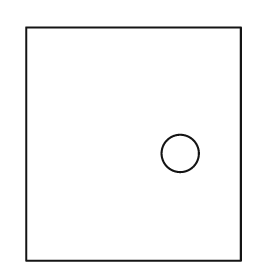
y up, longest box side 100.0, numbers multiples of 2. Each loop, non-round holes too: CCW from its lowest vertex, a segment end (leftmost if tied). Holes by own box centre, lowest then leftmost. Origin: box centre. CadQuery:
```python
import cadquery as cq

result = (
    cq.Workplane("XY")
    .moveTo(-46.0, -50.0)
    .lineTo(46.0, -50.0)
    .lineTo(46.0, 50.0)
    .lineTo(-46.0, 50.0)
    .close()
    .moveTo(20.0, -4.0)
    .circle(8.0)
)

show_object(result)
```